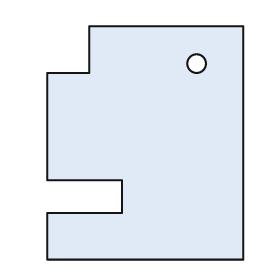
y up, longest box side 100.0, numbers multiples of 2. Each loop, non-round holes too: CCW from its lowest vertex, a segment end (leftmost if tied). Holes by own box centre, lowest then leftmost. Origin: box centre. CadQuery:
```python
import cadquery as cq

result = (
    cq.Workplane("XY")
    .moveTo(-42.0, -50.0)
    .lineTo(42.0, -50.0)
    .lineTo(42.0, 50.0)
    .lineTo(-24.0, 50.0)
    .lineTo(-24.0, 30.0)
    .lineTo(-42.0, 30.0)
    .lineTo(-42.0, -16.0)
    .lineTo(-10.0, -16.0)
    .lineTo(-10.0, -30.0)
    .lineTo(-42.0, -30.0)
    .close()
    .moveTo(22.0, 34.0)
    .circle(4.0)
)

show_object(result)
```